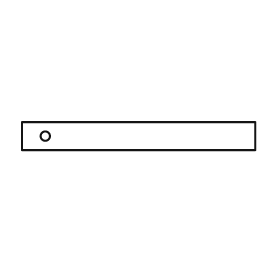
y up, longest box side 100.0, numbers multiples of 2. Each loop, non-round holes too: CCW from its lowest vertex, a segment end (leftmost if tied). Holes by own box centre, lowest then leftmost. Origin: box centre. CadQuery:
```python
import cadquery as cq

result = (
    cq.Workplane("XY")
    .moveTo(-50.0, -6.0)
    .lineTo(50.0, -6.0)
    .lineTo(50.0, 6.0)
    .lineTo(-50.0, 6.0)
    .close()
    .moveTo(-40.0, 0.0)
    .circle(2.0)
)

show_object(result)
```